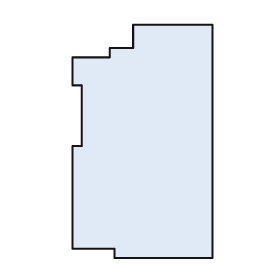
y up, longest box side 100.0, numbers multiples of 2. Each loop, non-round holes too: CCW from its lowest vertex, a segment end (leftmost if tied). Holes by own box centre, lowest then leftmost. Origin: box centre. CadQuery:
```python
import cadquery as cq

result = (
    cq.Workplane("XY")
    .moveTo(-12.0, -50.0)
    .lineTo(30.0, -50.0)
    .lineTo(30.0, 50.0)
    .lineTo(-4.0, 50.0)
    .lineTo(-4.0, 40.0)
    .lineTo(-14.0, 40.0)
    .lineTo(-14.0, 36.0)
    .lineTo(-30.0, 36.0)
    .lineTo(-30.0, 24.0)
    .lineTo(-26.0, 24.0)
    .lineTo(-26.0, -2.0)
    .lineTo(-30.0, -2.0)
    .lineTo(-30.0, -46.0)
    .lineTo(-12.0, -46.0)
    .close()
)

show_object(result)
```